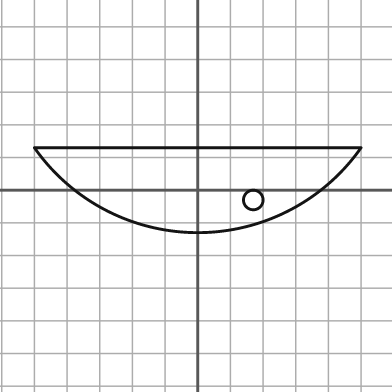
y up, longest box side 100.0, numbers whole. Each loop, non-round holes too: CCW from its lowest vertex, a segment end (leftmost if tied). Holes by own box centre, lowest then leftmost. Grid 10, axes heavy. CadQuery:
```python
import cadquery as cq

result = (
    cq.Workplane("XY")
    .moveTo(-50.0, 13.0)
    .threePointArc((0.0, -13.0), (50.0, 13.0))
    .close()
    .moveTo(17.0, -3.0)
    .circle(3.0)
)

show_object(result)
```